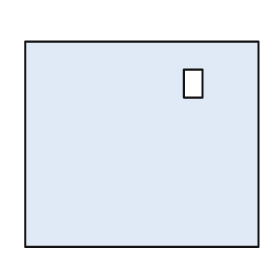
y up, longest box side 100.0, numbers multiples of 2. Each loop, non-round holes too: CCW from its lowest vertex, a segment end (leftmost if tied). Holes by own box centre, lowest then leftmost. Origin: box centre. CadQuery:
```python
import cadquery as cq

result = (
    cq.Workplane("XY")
    .moveTo(-50.0, -44.0)
    .lineTo(50.0, -44.0)
    .lineTo(50.0, 44.0)
    .lineTo(-50.0, 44.0)
    .close()
    .moveTo(18.0, 20.0)
    .lineTo(26.0, 20.0)
    .lineTo(26.0, 32.0)
    .lineTo(18.0, 32.0)
    .close()
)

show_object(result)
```